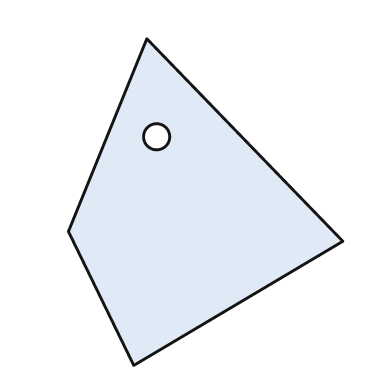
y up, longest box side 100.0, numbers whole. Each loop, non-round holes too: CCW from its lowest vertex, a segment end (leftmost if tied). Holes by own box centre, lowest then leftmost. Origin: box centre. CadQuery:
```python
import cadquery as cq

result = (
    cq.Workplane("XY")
    .moveTo(-22.0, -50.0)
    .lineTo(42.0, -12.0)
    .lineTo(-18.0, 50.0)
    .lineTo(-42.0, -9.0)
    .close()
    .moveTo(-15.0, 20.0)
    .circle(4.0)
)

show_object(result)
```